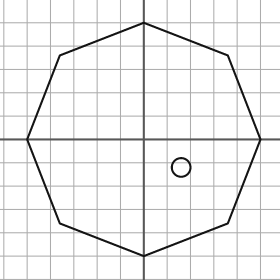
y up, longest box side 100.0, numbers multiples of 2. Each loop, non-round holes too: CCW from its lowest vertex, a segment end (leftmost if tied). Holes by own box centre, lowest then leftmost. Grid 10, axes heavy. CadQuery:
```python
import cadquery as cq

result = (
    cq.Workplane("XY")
    .moveTo(0.0, -50.0)
    .lineTo(36.0, -36.0)
    .lineTo(50.0, 0.0)
    .lineTo(36.0, 36.0)
    .lineTo(0.0, 50.0)
    .lineTo(-36.0, 36.0)
    .lineTo(-50.0, 0.0)
    .lineTo(-36.0, -36.0)
    .close()
    .moveTo(16.0, -12.0)
    .circle(4.0)
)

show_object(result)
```